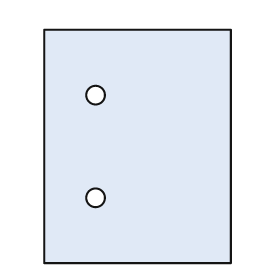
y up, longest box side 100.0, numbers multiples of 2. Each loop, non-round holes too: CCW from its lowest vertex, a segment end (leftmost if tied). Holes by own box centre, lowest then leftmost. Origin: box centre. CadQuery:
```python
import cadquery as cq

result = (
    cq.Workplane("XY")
    .moveTo(-40.0, -50.0)
    .lineTo(40.0, -50.0)
    .lineTo(40.0, 50.0)
    .lineTo(-40.0, 50.0)
    .close()
    .moveTo(-18.0, -22.0)
    .circle(4.0)
    .moveTo(-18.0, 22.0)
    .circle(4.0)
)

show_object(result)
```